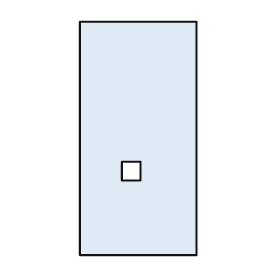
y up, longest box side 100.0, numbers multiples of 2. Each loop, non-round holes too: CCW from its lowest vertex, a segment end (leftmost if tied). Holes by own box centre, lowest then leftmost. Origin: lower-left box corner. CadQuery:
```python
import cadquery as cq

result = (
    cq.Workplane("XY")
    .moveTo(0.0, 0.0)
    .lineTo(50.0, 0.0)
    .lineTo(50.0, 100.0)
    .lineTo(0.0, 100.0)
    .close()
    .moveTo(18.0, 32.0)
    .lineTo(26.0, 32.0)
    .lineTo(26.0, 40.0)
    .lineTo(18.0, 40.0)
    .close()
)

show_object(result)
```